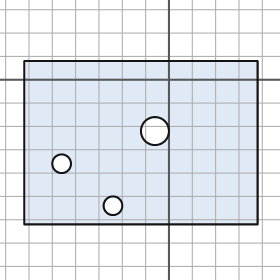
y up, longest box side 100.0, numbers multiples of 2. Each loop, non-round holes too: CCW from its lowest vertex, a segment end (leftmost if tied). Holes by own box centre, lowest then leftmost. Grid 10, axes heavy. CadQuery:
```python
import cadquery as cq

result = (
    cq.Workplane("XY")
    .moveTo(-62.0, -62.0)
    .lineTo(38.0, -62.0)
    .lineTo(38.0, 8.0)
    .lineTo(-62.0, 8.0)
    .close()
    .moveTo(-24.0, -54.0)
    .circle(4.0)
    .moveTo(-46.0, -36.0)
    .circle(4.0)
    .moveTo(-6.0, -22.0)
    .circle(6.0)
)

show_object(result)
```